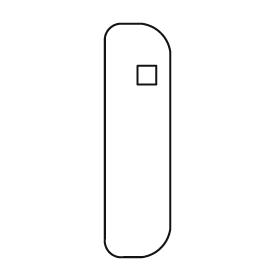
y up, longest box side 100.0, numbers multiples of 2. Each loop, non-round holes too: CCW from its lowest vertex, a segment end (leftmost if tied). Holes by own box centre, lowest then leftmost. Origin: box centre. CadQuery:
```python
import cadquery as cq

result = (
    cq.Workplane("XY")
    .moveTo(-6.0, -50.0)
    .lineTo(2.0, -50.0)
    .threePointArc((10.0, -46.0), (14.0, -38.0))
    .lineTo(14.0, 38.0)
    .threePointArc((10.0, 46.0), (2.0, 50.0))
    .lineTo(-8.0, 50.0)
    .threePointArc((-12.0, 48.0), (-14.0, 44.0))
    .lineTo(-14.0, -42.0)
    .threePointArc((-12.0, -48.0), (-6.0, -50.0))
    .close()
    .moveTo(0.0, 24.0)
    .lineTo(8.0, 24.0)
    .lineTo(8.0, 32.0)
    .lineTo(0.0, 32.0)
    .close()
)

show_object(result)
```